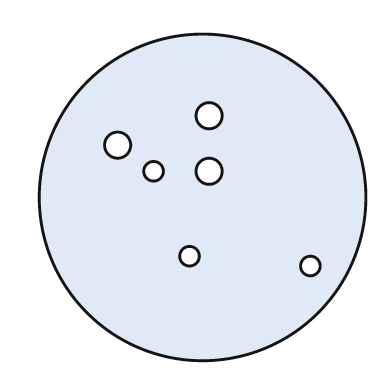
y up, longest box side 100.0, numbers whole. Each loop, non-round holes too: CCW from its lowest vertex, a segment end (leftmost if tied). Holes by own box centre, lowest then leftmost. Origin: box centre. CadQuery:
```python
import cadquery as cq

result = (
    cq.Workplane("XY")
    .moveTo(0.0, 0.0)
    .circle(50.0)
    .moveTo(33.0, -21.0)
    .circle(3.0)
    .moveTo(-4.0, -18.0)
    .circle(3.0)
    .moveTo(-15.0, 8.0)
    .circle(3.0)
    .moveTo(2.0, 8.0)
    .circle(4.0)
    .moveTo(-26.0, 16.0)
    .circle(4.0)
    .moveTo(2.0, 25.0)
    .circle(4.0)
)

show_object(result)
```